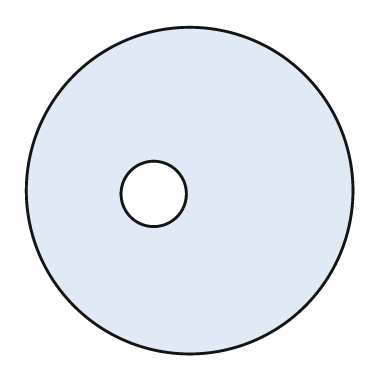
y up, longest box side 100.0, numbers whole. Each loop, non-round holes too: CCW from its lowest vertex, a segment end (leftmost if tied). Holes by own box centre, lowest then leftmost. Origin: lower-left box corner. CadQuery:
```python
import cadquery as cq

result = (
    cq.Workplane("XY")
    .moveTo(50.0, 50.0)
    .circle(50.0)
    .moveTo(39.0, 49.0)
    .circle(10.0)
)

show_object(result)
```